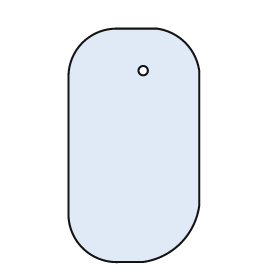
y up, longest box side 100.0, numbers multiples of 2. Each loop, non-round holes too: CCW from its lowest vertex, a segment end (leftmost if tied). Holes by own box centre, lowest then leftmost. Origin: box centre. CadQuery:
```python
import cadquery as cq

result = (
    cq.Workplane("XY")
    .moveTo(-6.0, -50.0)
    .lineTo(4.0, -50.0)
    .threePointArc((20.0, -42.0), (28.0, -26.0))
    .lineTo(28.0, 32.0)
    .threePointArc((22.0, 44.0), (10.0, 50.0))
    .lineTo(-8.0, 50.0)
    .threePointArc((-22.0, 44.0), (-28.0, 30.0))
    .lineTo(-28.0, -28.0)
    .threePointArc((-22.0, -44.0), (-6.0, -50.0))
    .close()
    .moveTo(4.0, 32.0)
    .circle(2.0)
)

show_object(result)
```